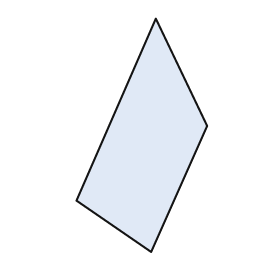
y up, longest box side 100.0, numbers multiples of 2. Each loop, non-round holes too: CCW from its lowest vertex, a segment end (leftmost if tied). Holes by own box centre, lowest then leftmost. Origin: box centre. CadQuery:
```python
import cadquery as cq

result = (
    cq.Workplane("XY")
    .moveTo(4.0, -50.0)
    .lineTo(28.0, 4.0)
    .lineTo(6.0, 50.0)
    .lineTo(-28.0, -28.0)
    .close()
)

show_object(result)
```